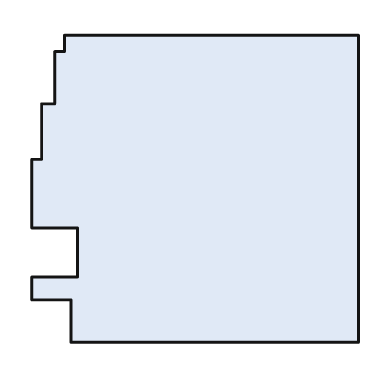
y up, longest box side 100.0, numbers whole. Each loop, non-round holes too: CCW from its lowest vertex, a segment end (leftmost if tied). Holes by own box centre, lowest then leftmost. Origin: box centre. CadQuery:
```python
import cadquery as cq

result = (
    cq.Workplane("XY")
    .moveTo(-38.0, -47.0)
    .lineTo(50.0, -47.0)
    .lineTo(50.0, 47.0)
    .lineTo(-40.0, 47.0)
    .lineTo(-40.0, 42.0)
    .lineTo(-43.0, 42.0)
    .lineTo(-43.0, 26.0)
    .lineTo(-47.0, 26.0)
    .lineTo(-47.0, 9.0)
    .lineTo(-50.0, 9.0)
    .lineTo(-50.0, -12.0)
    .lineTo(-36.0, -12.0)
    .lineTo(-36.0, -27.0)
    .lineTo(-50.0, -27.0)
    .lineTo(-50.0, -34.0)
    .lineTo(-38.0, -34.0)
    .close()
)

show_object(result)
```